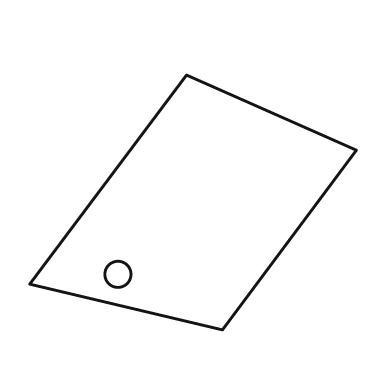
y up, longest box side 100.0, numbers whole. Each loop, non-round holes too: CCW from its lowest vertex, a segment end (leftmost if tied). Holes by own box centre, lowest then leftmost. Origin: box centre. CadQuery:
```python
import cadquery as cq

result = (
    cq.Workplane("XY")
    .moveTo(9.0, -39.0)
    .lineTo(50.0, 16.0)
    .lineTo(-2.0, 39.0)
    .lineTo(-50.0, -25.0)
    .close()
    .moveTo(-23.0, -22.0)
    .circle(4.0)
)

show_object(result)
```